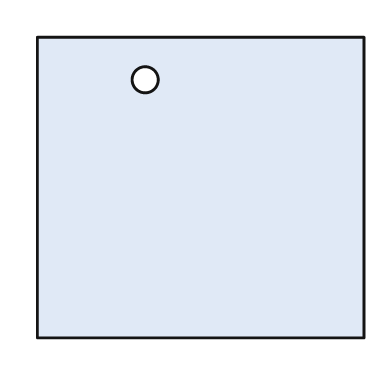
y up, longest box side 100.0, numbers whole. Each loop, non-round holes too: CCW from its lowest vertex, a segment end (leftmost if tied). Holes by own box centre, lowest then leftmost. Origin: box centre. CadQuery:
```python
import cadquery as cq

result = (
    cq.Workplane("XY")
    .moveTo(-50.0, -46.0)
    .lineTo(50.0, -46.0)
    .lineTo(50.0, 46.0)
    .lineTo(-50.0, 46.0)
    .close()
    .moveTo(-17.0, 33.0)
    .circle(4.0)
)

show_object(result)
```